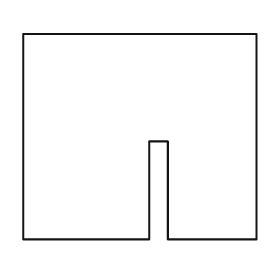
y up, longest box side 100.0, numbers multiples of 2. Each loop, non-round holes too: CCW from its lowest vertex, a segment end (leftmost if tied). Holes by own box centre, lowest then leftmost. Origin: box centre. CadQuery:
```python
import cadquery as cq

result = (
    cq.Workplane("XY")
    .moveTo(-50.0, -44.0)
    .lineTo(4.0, -44.0)
    .lineTo(4.0, -2.0)
    .lineTo(12.0, -2.0)
    .lineTo(12.0, -44.0)
    .lineTo(50.0, -44.0)
    .lineTo(50.0, 44.0)
    .lineTo(-50.0, 44.0)
    .close()
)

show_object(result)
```